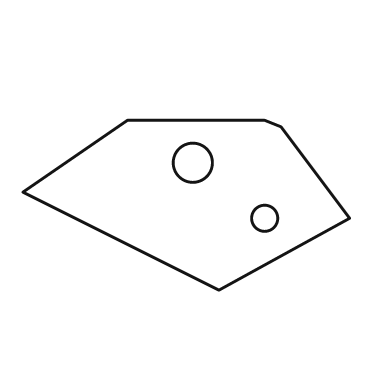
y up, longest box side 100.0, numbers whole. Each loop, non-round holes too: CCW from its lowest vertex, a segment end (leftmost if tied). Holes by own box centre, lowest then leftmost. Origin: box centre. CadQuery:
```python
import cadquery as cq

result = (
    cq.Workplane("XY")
    .moveTo(10.0, -26.0)
    .lineTo(50.0, -4.0)
    .lineTo(29.0, 24.0)
    .lineTo(24.0, 26.0)
    .lineTo(-18.0, 26.0)
    .lineTo(-50.0, 4.0)
    .close()
    .moveTo(24.0, -4.0)
    .circle(4.0)
    .moveTo(2.0, 13.0)
    .circle(6.0)
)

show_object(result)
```